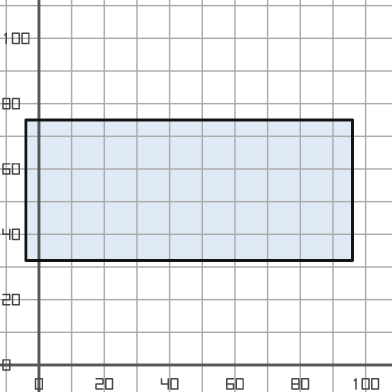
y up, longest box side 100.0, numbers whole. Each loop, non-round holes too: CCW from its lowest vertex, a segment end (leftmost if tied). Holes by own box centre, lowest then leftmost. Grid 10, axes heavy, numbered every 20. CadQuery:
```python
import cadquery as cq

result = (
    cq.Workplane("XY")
    .moveTo(-4.0, 32.0)
    .lineTo(96.0, 32.0)
    .lineTo(96.0, 75.0)
    .lineTo(-4.0, 75.0)
    .close()
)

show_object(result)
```